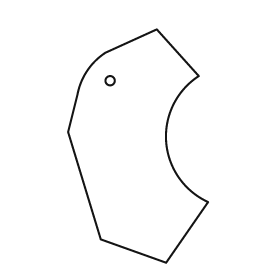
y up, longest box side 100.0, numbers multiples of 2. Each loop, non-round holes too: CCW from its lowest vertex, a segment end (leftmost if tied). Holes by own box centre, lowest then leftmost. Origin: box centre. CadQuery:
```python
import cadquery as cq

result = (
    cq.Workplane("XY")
    .moveTo(12.0, -50.0)
    .lineTo(30.0, -24.0)
    .threePointArc((12.0, 2.0), (26.0, 30.0))
    .lineTo(8.0, 50.0)
    .lineTo(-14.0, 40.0)
    .threePointArc((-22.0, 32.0), (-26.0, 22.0))
    .lineTo(-30.0, 6.0)
    .lineTo(-16.0, -40.0)
    .close()
    .moveTo(-12.0, 28.0)
    .circle(2.0)
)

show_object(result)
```